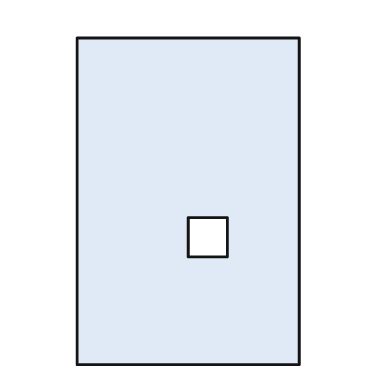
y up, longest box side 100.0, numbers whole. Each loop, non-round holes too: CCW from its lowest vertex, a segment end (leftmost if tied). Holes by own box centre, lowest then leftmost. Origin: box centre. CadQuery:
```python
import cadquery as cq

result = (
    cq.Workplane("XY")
    .moveTo(-34.0, -50.0)
    .lineTo(34.0, -50.0)
    .lineTo(34.0, 50.0)
    .lineTo(-34.0, 50.0)
    .close()
    .moveTo(0.0, -17.0)
    .lineTo(12.0, -17.0)
    .lineTo(12.0, -5.0)
    .lineTo(0.0, -5.0)
    .close()
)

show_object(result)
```